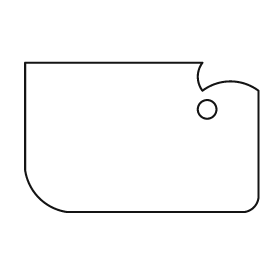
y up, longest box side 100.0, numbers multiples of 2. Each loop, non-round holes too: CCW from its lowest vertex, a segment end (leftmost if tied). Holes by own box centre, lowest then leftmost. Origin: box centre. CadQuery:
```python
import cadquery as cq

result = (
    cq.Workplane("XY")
    .moveTo(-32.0, -32.0)
    .lineTo(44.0, -32.0)
    .threePointArc((48.0, -30.0), (50.0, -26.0))
    .lineTo(50.0, 20.0)
    .threePointArc((38.0, 24.0), (26.0, 20.0))
    .threePointArc((24.0, 26.0), (26.0, 32.0))
    .lineTo(-50.0, 32.0)
    .lineTo(-50.0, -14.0)
    .threePointArc((-44.0, -26.0), (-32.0, -32.0))
    .close()
    .moveTo(28.0, 12.0)
    .circle(4.0)
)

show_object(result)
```